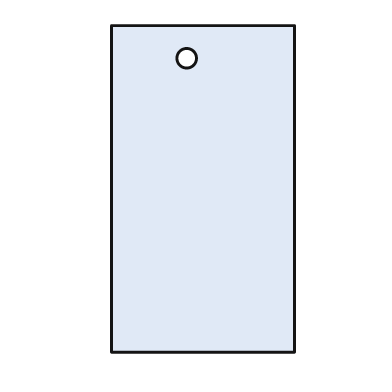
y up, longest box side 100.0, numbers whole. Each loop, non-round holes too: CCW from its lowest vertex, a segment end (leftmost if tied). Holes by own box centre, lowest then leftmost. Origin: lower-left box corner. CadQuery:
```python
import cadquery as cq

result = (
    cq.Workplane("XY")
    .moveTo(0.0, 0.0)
    .lineTo(56.0, 0.0)
    .lineTo(56.0, 100.0)
    .lineTo(0.0, 100.0)
    .close()
    .moveTo(23.0, 90.0)
    .circle(3.0)
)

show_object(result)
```